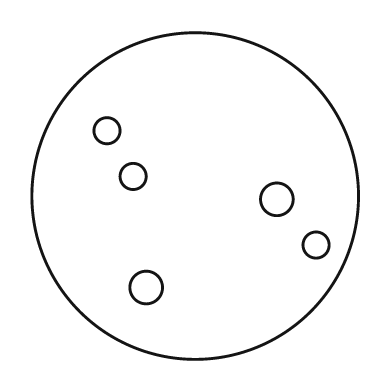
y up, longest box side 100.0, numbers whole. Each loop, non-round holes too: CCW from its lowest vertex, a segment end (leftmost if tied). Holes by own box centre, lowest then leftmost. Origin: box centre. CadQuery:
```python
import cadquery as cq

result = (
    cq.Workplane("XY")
    .moveTo(0.0, 0.0)
    .circle(50.0)
    .moveTo(-15.0, -28.0)
    .circle(5.0)
    .moveTo(37.0, -15.0)
    .circle(4.0)
    .moveTo(25.0, -1.0)
    .circle(5.0)
    .moveTo(-19.0, 6.0)
    .circle(4.0)
    .moveTo(-27.0, 20.0)
    .circle(4.0)
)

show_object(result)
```